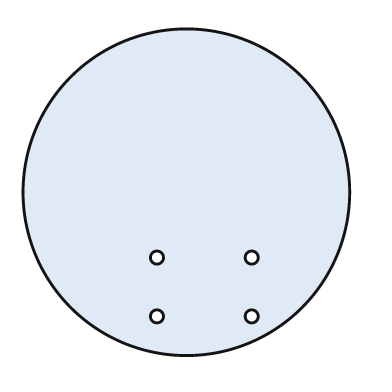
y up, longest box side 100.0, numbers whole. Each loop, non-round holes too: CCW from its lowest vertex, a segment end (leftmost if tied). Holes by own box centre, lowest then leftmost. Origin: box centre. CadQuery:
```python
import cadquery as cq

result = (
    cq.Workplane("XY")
    .moveTo(0.0, 0.0)
    .circle(50.0)
    .moveTo(-9.0, -38.0)
    .circle(2.0)
    .moveTo(20.0, -38.0)
    .circle(2.0)
    .moveTo(-9.0, -20.0)
    .circle(2.0)
    .moveTo(20.0, -20.0)
    .circle(2.0)
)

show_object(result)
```